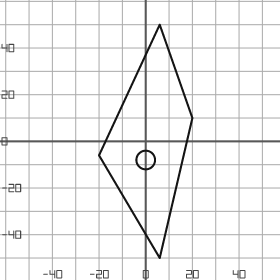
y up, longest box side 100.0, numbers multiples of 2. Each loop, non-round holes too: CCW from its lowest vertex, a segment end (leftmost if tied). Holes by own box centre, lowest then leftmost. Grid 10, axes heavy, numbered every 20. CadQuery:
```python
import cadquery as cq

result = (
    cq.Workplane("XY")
    .moveTo(6.0, -50.0)
    .lineTo(20.0, 10.0)
    .lineTo(6.0, 50.0)
    .lineTo(-20.0, -6.0)
    .close()
    .moveTo(0.0, -8.0)
    .circle(4.0)
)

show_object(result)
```